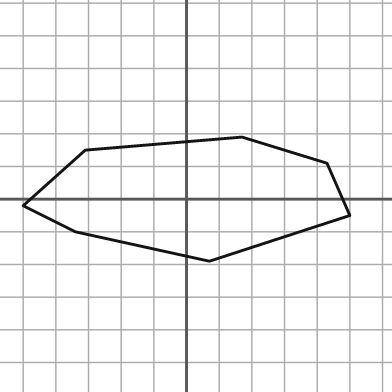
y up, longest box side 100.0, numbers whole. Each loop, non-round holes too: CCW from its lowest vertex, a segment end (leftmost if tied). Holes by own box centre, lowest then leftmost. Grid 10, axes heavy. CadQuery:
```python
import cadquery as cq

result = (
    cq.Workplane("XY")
    .moveTo(7.0, -19.0)
    .lineTo(50.0, -5.0)
    .lineTo(43.0, 11.0)
    .lineTo(17.0, 19.0)
    .lineTo(-31.0, 15.0)
    .lineTo(-50.0, -2.0)
    .lineTo(-34.0, -10.0)
    .close()
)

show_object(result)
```